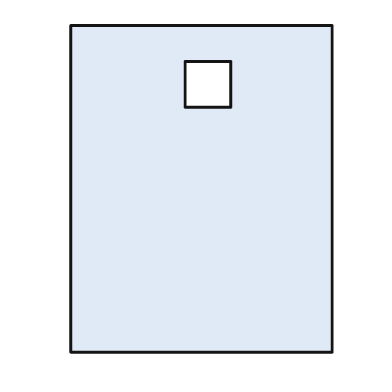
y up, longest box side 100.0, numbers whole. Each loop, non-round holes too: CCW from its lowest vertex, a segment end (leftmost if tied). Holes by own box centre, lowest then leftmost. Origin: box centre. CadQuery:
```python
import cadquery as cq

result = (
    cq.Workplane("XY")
    .moveTo(-40.0, -50.0)
    .lineTo(40.0, -50.0)
    .lineTo(40.0, 50.0)
    .lineTo(-40.0, 50.0)
    .close()
    .moveTo(-5.0, 25.0)
    .lineTo(9.0, 25.0)
    .lineTo(9.0, 39.0)
    .lineTo(-5.0, 39.0)
    .close()
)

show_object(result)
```